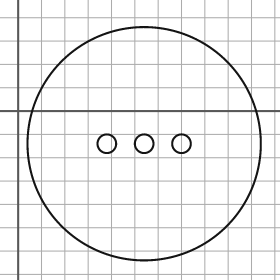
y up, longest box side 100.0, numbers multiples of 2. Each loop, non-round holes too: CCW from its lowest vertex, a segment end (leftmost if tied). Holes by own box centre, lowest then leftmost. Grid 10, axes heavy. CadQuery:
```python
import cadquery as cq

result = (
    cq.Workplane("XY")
    .moveTo(54.0, -14.0)
    .circle(50.0)
    .moveTo(38.0, -14.0)
    .circle(4.0)
    .moveTo(54.0, -14.0)
    .circle(4.0)
    .moveTo(70.0, -14.0)
    .circle(4.0)
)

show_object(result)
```